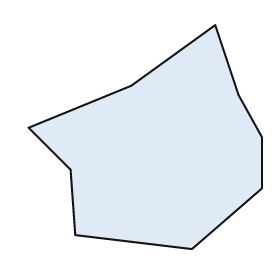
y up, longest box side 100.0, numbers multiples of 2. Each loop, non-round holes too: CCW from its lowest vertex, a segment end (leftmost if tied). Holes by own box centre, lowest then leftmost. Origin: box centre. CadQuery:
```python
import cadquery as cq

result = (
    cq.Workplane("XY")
    .moveTo(20.0, -48.0)
    .lineTo(50.0, -22.0)
    .lineTo(50.0, 0.0)
    .lineTo(40.0, 18.0)
    .lineTo(30.0, 48.0)
    .lineTo(-6.0, 22.0)
    .lineTo(-50.0, 4.0)
    .lineTo(-32.0, -14.0)
    .lineTo(-30.0, -42.0)
    .close()
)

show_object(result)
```